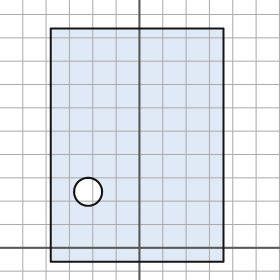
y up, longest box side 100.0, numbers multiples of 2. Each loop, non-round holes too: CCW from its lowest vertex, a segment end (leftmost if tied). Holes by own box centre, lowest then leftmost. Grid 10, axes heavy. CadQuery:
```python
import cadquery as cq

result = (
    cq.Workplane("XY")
    .moveTo(-38.0, -6.0)
    .lineTo(36.0, -6.0)
    .lineTo(36.0, 94.0)
    .lineTo(-38.0, 94.0)
    .close()
    .moveTo(-22.0, 24.0)
    .circle(6.0)
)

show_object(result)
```